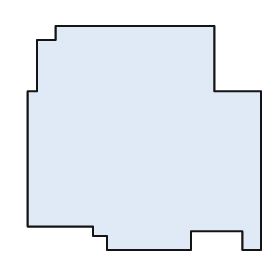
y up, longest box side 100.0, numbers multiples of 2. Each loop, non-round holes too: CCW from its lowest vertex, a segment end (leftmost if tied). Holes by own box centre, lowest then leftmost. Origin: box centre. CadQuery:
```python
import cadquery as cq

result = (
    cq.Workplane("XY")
    .moveTo(-16.0, -48.0)
    .lineTo(20.0, -48.0)
    .lineTo(20.0, -40.0)
    .lineTo(42.0, -40.0)
    .lineTo(42.0, -48.0)
    .lineTo(50.0, -48.0)
    .lineTo(50.0, 20.0)
    .lineTo(30.0, 20.0)
    .lineTo(30.0, 48.0)
    .lineTo(-38.0, 48.0)
    .lineTo(-38.0, 42.0)
    .lineTo(-46.0, 42.0)
    .lineTo(-46.0, 20.0)
    .lineTo(-50.0, 20.0)
    .lineTo(-50.0, -38.0)
    .lineTo(-22.0, -38.0)
    .lineTo(-22.0, -42.0)
    .lineTo(-16.0, -42.0)
    .close()
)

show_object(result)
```